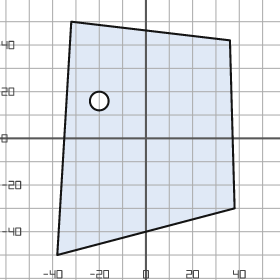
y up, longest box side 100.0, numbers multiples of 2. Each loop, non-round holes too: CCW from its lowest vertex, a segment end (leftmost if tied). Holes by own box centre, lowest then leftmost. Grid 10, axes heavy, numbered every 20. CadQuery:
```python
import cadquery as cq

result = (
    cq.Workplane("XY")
    .moveTo(-38.0, -50.0)
    .lineTo(38.0, -30.0)
    .lineTo(36.0, 42.0)
    .lineTo(-32.0, 50.0)
    .close()
    .moveTo(-20.0, 16.0)
    .circle(4.0)
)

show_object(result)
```